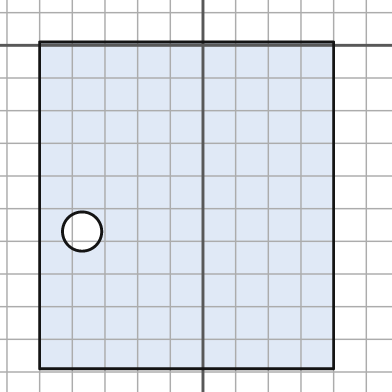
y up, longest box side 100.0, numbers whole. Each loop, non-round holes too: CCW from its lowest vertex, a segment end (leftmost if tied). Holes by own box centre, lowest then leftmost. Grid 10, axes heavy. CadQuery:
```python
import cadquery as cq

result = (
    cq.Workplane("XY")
    .moveTo(-50.0, -99.0)
    .lineTo(40.0, -99.0)
    .lineTo(40.0, 1.0)
    .lineTo(-50.0, 1.0)
    .close()
    .moveTo(-37.0, -57.0)
    .circle(6.0)
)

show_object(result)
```